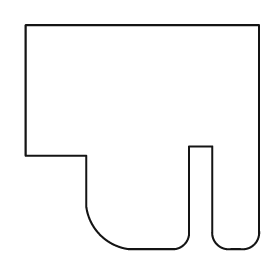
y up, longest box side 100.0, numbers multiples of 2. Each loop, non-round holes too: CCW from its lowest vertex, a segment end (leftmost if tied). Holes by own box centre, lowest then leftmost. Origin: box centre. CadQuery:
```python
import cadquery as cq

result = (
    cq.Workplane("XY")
    .moveTo(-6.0, -48.0)
    .lineTo(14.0, -48.0)
    .threePointArc((18.0, -46.0), (20.0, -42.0))
    .lineTo(20.0, -4.0)
    .lineTo(30.0, -4.0)
    .lineTo(30.0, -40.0)
    .threePointArc((32.0, -46.0), (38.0, -48.0))
    .lineTo(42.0, -48.0)
    .threePointArc((48.0, -46.0), (50.0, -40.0))
    .lineTo(50.0, 48.0)
    .lineTo(-50.0, 48.0)
    .lineTo(-50.0, -8.0)
    .lineTo(-24.0, -8.0)
    .lineTo(-24.0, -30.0)
    .threePointArc((-18.0, -42.0), (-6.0, -48.0))
    .close()
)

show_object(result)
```